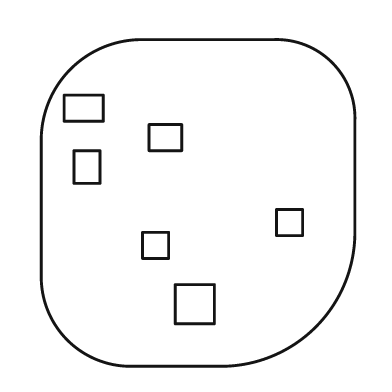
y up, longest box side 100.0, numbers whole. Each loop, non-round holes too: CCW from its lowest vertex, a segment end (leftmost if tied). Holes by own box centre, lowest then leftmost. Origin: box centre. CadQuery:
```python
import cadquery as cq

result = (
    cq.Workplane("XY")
    .moveTo(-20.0, -50.0)
    .lineTo(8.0, -50.0)
    .threePointArc((36.0, -38.0), (48.0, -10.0))
    .lineTo(48.0, 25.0)
    .threePointArc((41.0, 43.0), (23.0, 50.0))
    .lineTo(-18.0, 50.0)
    .threePointArc((-39.0, 41.0), (-48.0, 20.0))
    .lineTo(-48.0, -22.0)
    .threePointArc((-40.0, -42.0), (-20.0, -50.0))
    .close()
    .moveTo(-7.0, -37.0)
    .lineTo(5.0, -37.0)
    .lineTo(5.0, -25.0)
    .lineTo(-7.0, -25.0)
    .close()
    .moveTo(-17.0, -17.0)
    .lineTo(-9.0, -17.0)
    .lineTo(-9.0, -9.0)
    .lineTo(-17.0, -9.0)
    .close()
    .moveTo(24.0, -10.0)
    .lineTo(32.0, -10.0)
    .lineTo(32.0, -2.0)
    .lineTo(24.0, -2.0)
    .close()
    .moveTo(-38.0, 6.0)
    .lineTo(-30.0, 6.0)
    .lineTo(-30.0, 16.0)
    .lineTo(-38.0, 16.0)
    .close()
    .moveTo(-15.0, 16.0)
    .lineTo(-5.0, 16.0)
    .lineTo(-5.0, 24.0)
    .lineTo(-15.0, 24.0)
    .close()
    .moveTo(-41.0, 25.0)
    .lineTo(-29.0, 25.0)
    .lineTo(-29.0, 33.0)
    .lineTo(-41.0, 33.0)
    .close()
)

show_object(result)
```